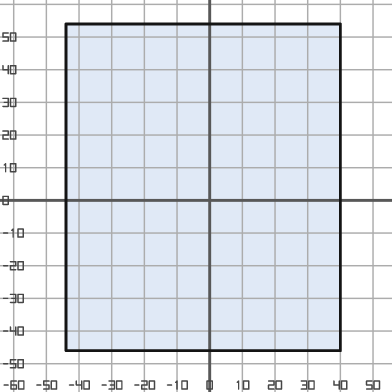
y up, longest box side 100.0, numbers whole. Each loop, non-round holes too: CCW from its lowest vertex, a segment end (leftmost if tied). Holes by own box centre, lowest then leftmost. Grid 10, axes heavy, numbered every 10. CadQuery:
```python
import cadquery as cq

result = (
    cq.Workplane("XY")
    .moveTo(-44.0, -46.0)
    .lineTo(40.0, -46.0)
    .lineTo(40.0, 54.0)
    .lineTo(-44.0, 54.0)
    .close()
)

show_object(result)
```